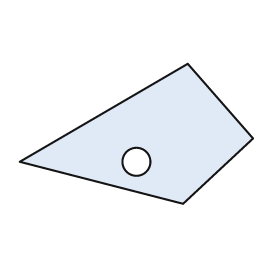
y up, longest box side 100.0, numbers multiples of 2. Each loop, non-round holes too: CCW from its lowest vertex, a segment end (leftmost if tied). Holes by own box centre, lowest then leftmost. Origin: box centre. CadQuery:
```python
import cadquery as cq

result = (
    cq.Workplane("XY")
    .moveTo(20.0, -30.0)
    .lineTo(50.0, -2.0)
    .lineTo(22.0, 30.0)
    .lineTo(-50.0, -12.0)
    .close()
    .moveTo(0.0, -12.0)
    .circle(6.0)
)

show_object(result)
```